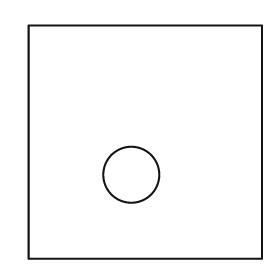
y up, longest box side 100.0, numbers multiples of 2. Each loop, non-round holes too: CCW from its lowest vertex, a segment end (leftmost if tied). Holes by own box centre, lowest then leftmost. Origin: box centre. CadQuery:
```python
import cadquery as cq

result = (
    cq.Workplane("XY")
    .moveTo(-50.0, -50.0)
    .lineTo(50.0, -50.0)
    .lineTo(50.0, 50.0)
    .lineTo(-50.0, 50.0)
    .close()
    .moveTo(-6.0, -14.0)
    .circle(12.0)
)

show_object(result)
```